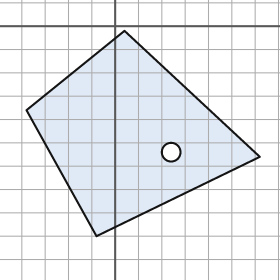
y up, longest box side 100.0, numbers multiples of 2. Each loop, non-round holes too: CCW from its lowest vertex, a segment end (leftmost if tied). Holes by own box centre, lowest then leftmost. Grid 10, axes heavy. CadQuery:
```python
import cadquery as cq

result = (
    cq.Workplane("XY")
    .moveTo(-8.0, -90.0)
    .lineTo(62.0, -56.0)
    .lineTo(4.0, -2.0)
    .lineTo(-38.0, -36.0)
    .close()
    .moveTo(24.0, -54.0)
    .circle(4.0)
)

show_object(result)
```